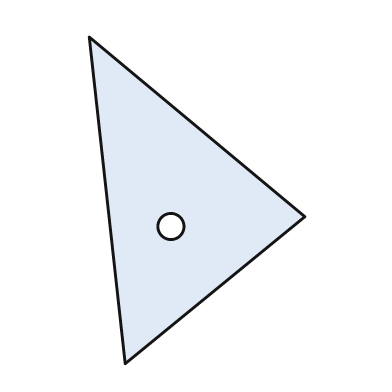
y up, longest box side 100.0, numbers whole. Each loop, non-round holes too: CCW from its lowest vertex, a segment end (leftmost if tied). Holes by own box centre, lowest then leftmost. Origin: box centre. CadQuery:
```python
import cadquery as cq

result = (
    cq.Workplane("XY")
    .moveTo(-22.0, -50.0)
    .lineTo(33.0, -5.0)
    .lineTo(-33.0, 50.0)
    .close()
    .moveTo(-8.0, -8.0)
    .circle(4.0)
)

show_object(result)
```